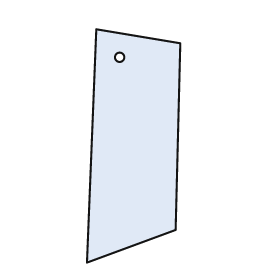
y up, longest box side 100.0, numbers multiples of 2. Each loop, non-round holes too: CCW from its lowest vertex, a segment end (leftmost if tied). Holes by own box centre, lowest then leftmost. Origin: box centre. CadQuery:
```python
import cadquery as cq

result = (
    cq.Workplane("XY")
    .moveTo(-20.0, -50.0)
    .lineTo(18.0, -36.0)
    .lineTo(20.0, 44.0)
    .lineTo(-16.0, 50.0)
    .close()
    .moveTo(-6.0, 38.0)
    .circle(2.0)
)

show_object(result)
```